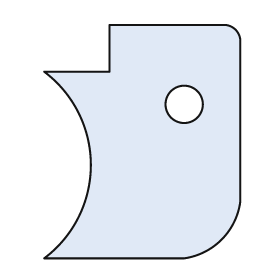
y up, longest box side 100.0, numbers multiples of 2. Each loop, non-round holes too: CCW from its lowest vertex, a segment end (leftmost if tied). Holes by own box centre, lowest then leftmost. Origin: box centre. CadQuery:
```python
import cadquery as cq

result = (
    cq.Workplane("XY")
    .moveTo(-42.0, -50.0)
    .lineTo(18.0, -50.0)
    .threePointArc((34.0, -42.0), (42.0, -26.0))
    .lineTo(42.0, 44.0)
    .threePointArc((40.0, 48.0), (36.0, 50.0))
    .lineTo(-14.0, 50.0)
    .lineTo(-14.0, 30.0)
    .lineTo(-42.0, 30.0)
    .threePointArc((-22.0, -10.0), (-42.0, -50.0))
    .close()
    .moveTo(18.0, 16.0)
    .circle(8.0)
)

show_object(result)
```